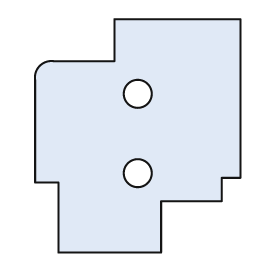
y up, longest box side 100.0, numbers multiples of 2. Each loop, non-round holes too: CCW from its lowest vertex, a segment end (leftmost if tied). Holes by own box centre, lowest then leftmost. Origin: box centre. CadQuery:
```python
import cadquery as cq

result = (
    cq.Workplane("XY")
    .moveTo(-34.0, -50.0)
    .lineTo(10.0, -50.0)
    .lineTo(10.0, -28.0)
    .lineTo(36.0, -28.0)
    .lineTo(36.0, -18.0)
    .lineTo(44.0, -18.0)
    .lineTo(44.0, 50.0)
    .lineTo(-10.0, 50.0)
    .lineTo(-10.0, 32.0)
    .lineTo(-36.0, 32.0)
    .threePointArc((-42.0, 30.0), (-44.0, 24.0))
    .lineTo(-44.0, -20.0)
    .lineTo(-34.0, -20.0)
    .close()
    .moveTo(0.0, -16.0)
    .circle(6.0)
    .moveTo(0.0, 18.0)
    .circle(6.0)
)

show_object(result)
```